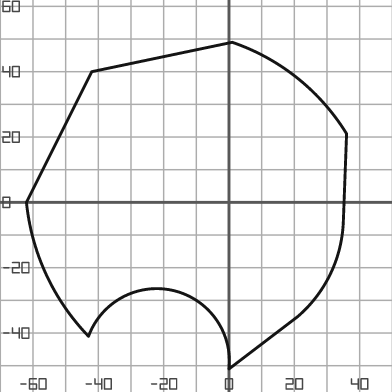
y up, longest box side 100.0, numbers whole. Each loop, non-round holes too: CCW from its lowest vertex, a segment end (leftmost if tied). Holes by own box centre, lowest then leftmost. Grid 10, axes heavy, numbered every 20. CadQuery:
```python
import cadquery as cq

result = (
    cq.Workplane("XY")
    .moveTo(0.0, -51.0)
    .lineTo(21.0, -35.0)
    .threePointArc((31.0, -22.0), (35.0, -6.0))
    .lineTo(36.0, 21.0)
    .threePointArc((21.0, 38.0), (1.0, 49.0))
    .lineTo(-42.0, 40.0)
    .lineTo(-62.0, 0.0)
    .threePointArc((-56.0, -22.0), (-43.0, -41.0))
    .threePointArc((-17.0, -27.0), (0.0, -51.0))
    .close()
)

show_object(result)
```